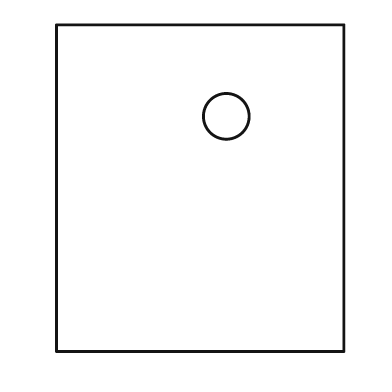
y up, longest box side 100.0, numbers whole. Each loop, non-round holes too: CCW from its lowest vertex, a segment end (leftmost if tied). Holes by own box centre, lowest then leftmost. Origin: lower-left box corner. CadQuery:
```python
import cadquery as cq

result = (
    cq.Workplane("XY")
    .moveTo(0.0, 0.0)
    .lineTo(88.0, 0.0)
    .lineTo(88.0, 100.0)
    .lineTo(0.0, 100.0)
    .close()
    .moveTo(52.0, 72.0)
    .circle(7.0)
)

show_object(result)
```